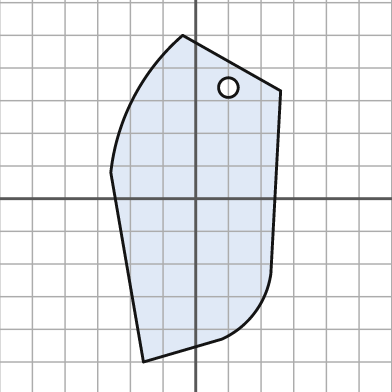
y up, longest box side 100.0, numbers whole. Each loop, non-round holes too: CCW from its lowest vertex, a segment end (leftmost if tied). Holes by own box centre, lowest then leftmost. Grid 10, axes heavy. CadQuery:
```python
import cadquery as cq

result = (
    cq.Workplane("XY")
    .moveTo(-16.0, -50.0)
    .lineTo(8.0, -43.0)
    .threePointArc((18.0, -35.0), (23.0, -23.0))
    .lineTo(26.0, 33.0)
    .lineTo(-4.0, 50.0)
    .threePointArc((-19.0, 31.0), (-26.0, 8.0))
    .close()
    .moveTo(10.0, 34.0)
    .circle(3.0)
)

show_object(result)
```